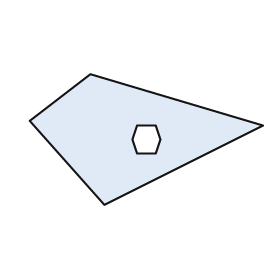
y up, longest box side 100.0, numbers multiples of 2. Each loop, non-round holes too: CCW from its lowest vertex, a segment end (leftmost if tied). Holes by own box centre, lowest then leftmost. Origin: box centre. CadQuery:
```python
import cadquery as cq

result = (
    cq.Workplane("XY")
    .moveTo(-18.0, -28.0)
    .lineTo(50.0, 6.0)
    .lineTo(-24.0, 28.0)
    .lineTo(-50.0, 8.0)
    .close()
    .moveTo(-4.0, -6.0)
    .lineTo(4.0, -6.0)
    .lineTo(6.0, 0.0)
    .lineTo(4.0, 6.0)
    .lineTo(-4.0, 6.0)
    .lineTo(-6.0, 0.0)
    .close()
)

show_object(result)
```